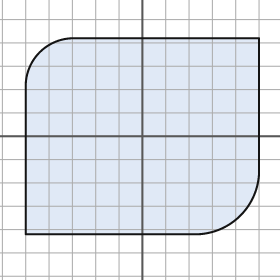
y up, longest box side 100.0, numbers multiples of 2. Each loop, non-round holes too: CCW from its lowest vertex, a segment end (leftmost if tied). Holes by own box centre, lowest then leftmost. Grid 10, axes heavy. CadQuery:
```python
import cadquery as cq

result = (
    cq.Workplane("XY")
    .moveTo(-50.0, -42.0)
    .lineTo(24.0, -42.0)
    .threePointArc((42.0, -34.0), (50.0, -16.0))
    .lineTo(50.0, 42.0)
    .lineTo(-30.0, 42.0)
    .threePointArc((-44.0, 36.0), (-50.0, 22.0))
    .close()
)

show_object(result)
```